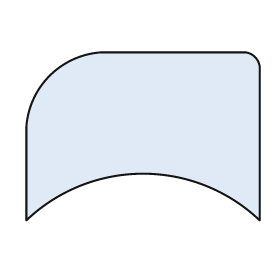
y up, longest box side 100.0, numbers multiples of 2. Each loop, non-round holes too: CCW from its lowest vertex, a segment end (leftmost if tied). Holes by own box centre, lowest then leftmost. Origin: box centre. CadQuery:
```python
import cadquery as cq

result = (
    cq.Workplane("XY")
    .moveTo(-50.0, -36.0)
    .threePointArc((0.0, -16.0), (50.0, -36.0))
    .lineTo(50.0, 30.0)
    .threePointArc((48.0, 34.0), (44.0, 36.0))
    .lineTo(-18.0, 36.0)
    .threePointArc((-40.0, 26.0), (-50.0, 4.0))
    .close()
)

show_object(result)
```